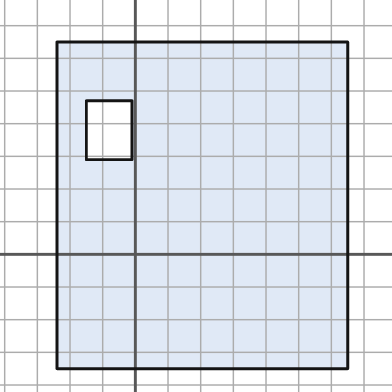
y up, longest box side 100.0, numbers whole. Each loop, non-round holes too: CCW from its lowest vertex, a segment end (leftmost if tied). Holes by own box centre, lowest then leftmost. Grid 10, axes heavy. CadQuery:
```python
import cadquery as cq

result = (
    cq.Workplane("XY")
    .moveTo(-24.0, -35.0)
    .lineTo(65.0, -35.0)
    .lineTo(65.0, 65.0)
    .lineTo(-24.0, 65.0)
    .close()
    .moveTo(-15.0, 29.0)
    .lineTo(-1.0, 29.0)
    .lineTo(-1.0, 47.0)
    .lineTo(-15.0, 47.0)
    .close()
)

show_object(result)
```